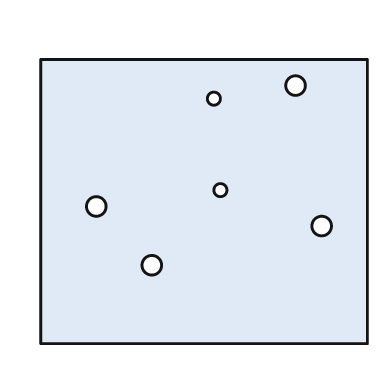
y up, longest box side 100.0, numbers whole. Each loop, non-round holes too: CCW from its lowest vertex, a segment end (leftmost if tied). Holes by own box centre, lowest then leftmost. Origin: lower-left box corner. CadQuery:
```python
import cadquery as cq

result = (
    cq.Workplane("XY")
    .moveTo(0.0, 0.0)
    .lineTo(100.0, 0.0)
    .lineTo(100.0, 87.0)
    .lineTo(0.0, 87.0)
    .close()
    .moveTo(34.0, 24.0)
    .circle(3.0)
    .moveTo(86.0, 36.0)
    .circle(3.0)
    .moveTo(17.0, 42.0)
    .circle(3.0)
    .moveTo(55.0, 47.0)
    .circle(2.0)
    .moveTo(53.0, 75.0)
    .circle(2.0)
    .moveTo(78.0, 79.0)
    .circle(3.0)
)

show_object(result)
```